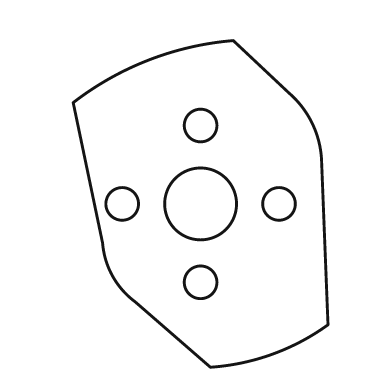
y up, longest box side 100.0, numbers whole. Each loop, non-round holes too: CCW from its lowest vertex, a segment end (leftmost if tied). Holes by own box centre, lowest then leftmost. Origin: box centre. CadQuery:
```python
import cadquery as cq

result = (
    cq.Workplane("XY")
    .moveTo(3.0, -50.0)
    .threePointArc((22.0, -46.0), (39.0, -37.0))
    .lineTo(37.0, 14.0)
    .threePointArc((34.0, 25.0), (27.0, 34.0))
    .lineTo(10.0, 50.0)
    .threePointArc((-16.0, 44.0), (-39.0, 31.0))
    .lineTo(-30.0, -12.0)
    .threePointArc((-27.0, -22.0), (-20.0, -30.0))
    .close()
    .moveTo(0.0, -24.0)
    .circle(5.0)
    .moveTo(-24.0, 0.0)
    .circle(5.0)
    .moveTo(0.0, 0.0)
    .circle(11.0)
    .moveTo(24.0, 0.0)
    .circle(5.0)
    .moveTo(0.0, 24.0)
    .circle(5.0)
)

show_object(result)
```